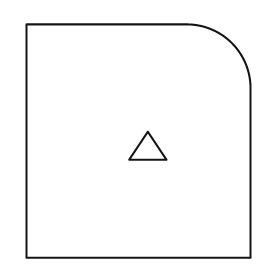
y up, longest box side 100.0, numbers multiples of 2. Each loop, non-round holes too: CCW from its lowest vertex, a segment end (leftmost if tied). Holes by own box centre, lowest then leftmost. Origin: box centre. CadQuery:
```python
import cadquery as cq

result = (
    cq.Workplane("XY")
    .moveTo(-48.0, -50.0)
    .lineTo(48.0, -50.0)
    .lineTo(48.0, 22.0)
    .threePointArc((40.0, 42.0), (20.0, 50.0))
    .lineTo(-48.0, 50.0)
    .close()
    .moveTo(-4.0, -8.0)
    .lineTo(12.0, -8.0)
    .lineTo(4.0, 4.0)
    .close()
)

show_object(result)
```